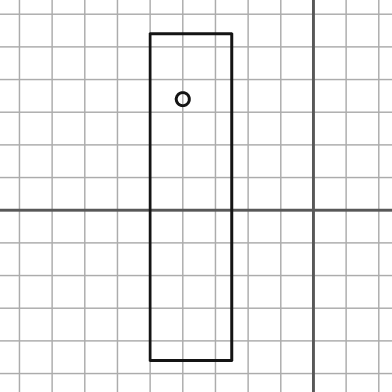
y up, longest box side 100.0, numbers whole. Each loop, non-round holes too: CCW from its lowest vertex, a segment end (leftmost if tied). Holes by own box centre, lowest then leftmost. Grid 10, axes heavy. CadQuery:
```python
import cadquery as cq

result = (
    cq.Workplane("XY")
    .moveTo(-50.0, -46.0)
    .lineTo(-25.0, -46.0)
    .lineTo(-25.0, 54.0)
    .lineTo(-50.0, 54.0)
    .close()
    .moveTo(-40.0, 34.0)
    .circle(2.0)
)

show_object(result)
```